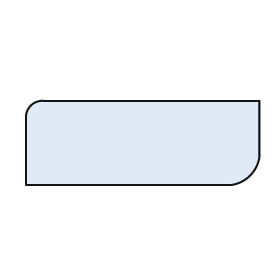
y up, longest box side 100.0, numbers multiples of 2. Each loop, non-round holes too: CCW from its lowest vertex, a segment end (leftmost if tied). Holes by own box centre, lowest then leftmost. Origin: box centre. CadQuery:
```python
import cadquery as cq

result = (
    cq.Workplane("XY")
    .moveTo(-50.0, -18.0)
    .lineTo(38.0, -18.0)
    .threePointArc((46.0, -14.0), (50.0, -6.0))
    .lineTo(50.0, 18.0)
    .lineTo(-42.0, 18.0)
    .threePointArc((-48.0, 16.0), (-50.0, 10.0))
    .close()
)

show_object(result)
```